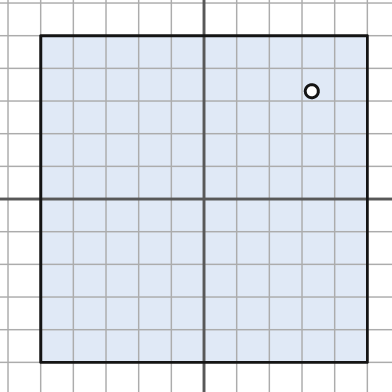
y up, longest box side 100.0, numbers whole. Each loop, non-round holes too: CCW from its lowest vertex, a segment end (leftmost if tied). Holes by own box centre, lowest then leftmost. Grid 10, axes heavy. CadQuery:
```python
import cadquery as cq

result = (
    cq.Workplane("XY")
    .moveTo(-50.0, -50.0)
    .lineTo(50.0, -50.0)
    .lineTo(50.0, 50.0)
    .lineTo(-50.0, 50.0)
    .close()
    .moveTo(33.0, 33.0)
    .circle(2.0)
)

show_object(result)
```